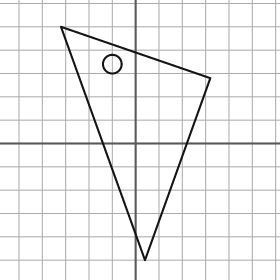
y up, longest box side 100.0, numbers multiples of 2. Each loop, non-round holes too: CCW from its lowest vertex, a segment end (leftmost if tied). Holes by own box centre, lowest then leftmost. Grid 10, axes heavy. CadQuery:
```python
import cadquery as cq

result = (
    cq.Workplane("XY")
    .moveTo(4.0, -50.0)
    .lineTo(32.0, 28.0)
    .lineTo(-32.0, 50.0)
    .close()
    .moveTo(-10.0, 34.0)
    .circle(4.0)
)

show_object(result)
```